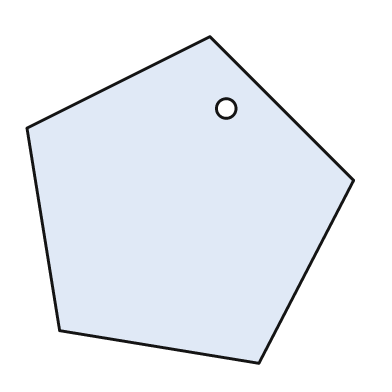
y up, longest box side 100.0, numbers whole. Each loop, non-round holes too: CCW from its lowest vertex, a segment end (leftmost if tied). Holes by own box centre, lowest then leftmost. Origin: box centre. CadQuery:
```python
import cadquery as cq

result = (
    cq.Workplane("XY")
    .moveTo(21.0, -50.0)
    .lineTo(50.0, 6.0)
    .lineTo(6.0, 50.0)
    .lineTo(-50.0, 22.0)
    .lineTo(-40.0, -40.0)
    .close()
    .moveTo(11.0, 28.0)
    .circle(3.0)
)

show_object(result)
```